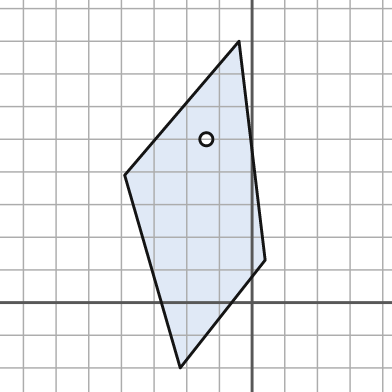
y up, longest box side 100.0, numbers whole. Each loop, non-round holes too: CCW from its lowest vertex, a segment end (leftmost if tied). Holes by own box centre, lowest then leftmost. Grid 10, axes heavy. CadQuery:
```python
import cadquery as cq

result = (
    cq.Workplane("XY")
    .moveTo(-22.0, -20.0)
    .lineTo(4.0, 13.0)
    .lineTo(-4.0, 80.0)
    .lineTo(-39.0, 39.0)
    .close()
    .moveTo(-14.0, 50.0)
    .circle(2.0)
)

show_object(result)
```